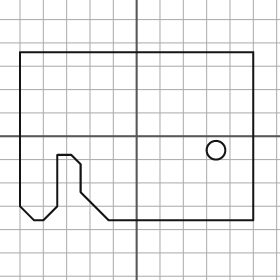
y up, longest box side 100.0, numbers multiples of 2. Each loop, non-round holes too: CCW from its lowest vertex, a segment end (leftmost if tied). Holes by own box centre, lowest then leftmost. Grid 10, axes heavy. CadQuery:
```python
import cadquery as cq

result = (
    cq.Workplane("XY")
    .moveTo(-44.0, -36.0)
    .lineTo(-40.0, -36.0)
    .lineTo(-34.0, -30.0)
    .lineTo(-34.0, -8.0)
    .lineTo(-28.0, -8.0)
    .lineTo(-24.0, -12.0)
    .lineTo(-24.0, -24.0)
    .lineTo(-12.0, -36.0)
    .lineTo(50.0, -36.0)
    .lineTo(50.0, 36.0)
    .lineTo(-50.0, 36.0)
    .lineTo(-50.0, -30.0)
    .close()
    .moveTo(34.0, -6.0)
    .circle(4.0)
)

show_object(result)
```